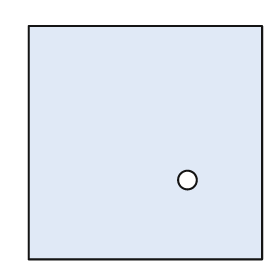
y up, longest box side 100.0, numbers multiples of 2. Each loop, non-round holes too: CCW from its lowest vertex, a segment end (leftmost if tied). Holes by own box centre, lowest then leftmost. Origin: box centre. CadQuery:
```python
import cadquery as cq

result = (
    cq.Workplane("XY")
    .moveTo(-50.0, -50.0)
    .lineTo(50.0, -50.0)
    .lineTo(50.0, 50.0)
    .lineTo(-50.0, 50.0)
    .close()
    .moveTo(18.0, -16.0)
    .circle(4.0)
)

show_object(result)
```